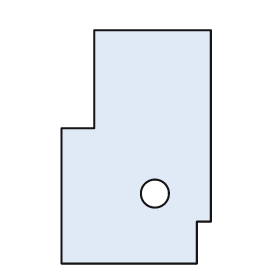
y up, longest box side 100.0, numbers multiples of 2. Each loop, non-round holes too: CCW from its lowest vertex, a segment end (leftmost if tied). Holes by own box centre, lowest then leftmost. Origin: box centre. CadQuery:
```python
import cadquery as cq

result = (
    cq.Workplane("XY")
    .moveTo(-32.0, -50.0)
    .lineTo(26.0, -50.0)
    .lineTo(26.0, -32.0)
    .lineTo(32.0, -32.0)
    .lineTo(32.0, 50.0)
    .lineTo(-18.0, 50.0)
    .lineTo(-18.0, 8.0)
    .lineTo(-32.0, 8.0)
    .close()
    .moveTo(8.0, -20.0)
    .circle(6.0)
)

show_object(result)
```